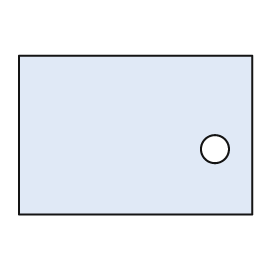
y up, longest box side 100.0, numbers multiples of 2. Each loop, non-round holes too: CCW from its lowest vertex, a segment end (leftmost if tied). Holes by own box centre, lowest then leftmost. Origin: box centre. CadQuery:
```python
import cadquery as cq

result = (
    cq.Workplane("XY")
    .moveTo(-50.0, -34.0)
    .lineTo(50.0, -34.0)
    .lineTo(50.0, 34.0)
    .lineTo(-50.0, 34.0)
    .close()
    .moveTo(34.0, -6.0)
    .circle(6.0)
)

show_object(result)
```